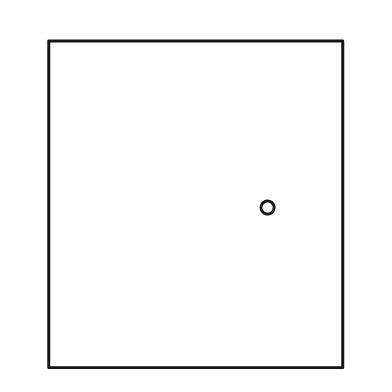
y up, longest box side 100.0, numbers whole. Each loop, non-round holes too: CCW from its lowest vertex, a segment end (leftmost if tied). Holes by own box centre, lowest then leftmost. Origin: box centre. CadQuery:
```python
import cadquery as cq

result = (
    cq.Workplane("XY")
    .moveTo(-45.0, -50.0)
    .lineTo(45.0, -50.0)
    .lineTo(45.0, 50.0)
    .lineTo(-45.0, 50.0)
    .close()
    .moveTo(22.0, -1.0)
    .circle(2.0)
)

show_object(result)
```